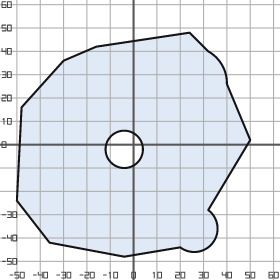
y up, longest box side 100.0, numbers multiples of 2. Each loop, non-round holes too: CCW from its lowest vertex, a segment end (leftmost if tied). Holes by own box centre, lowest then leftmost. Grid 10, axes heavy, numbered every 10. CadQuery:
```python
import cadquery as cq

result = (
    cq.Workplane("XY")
    .moveTo(-4.0, -48.0)
    .lineTo(20.0, -44.0)
    .threePointArc((34.0, -42.0), (32.0, -28.0))
    .lineTo(50.0, 2.0)
    .lineTo(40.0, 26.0)
    .threePointArc((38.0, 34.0), (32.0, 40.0))
    .lineTo(24.0, 48.0)
    .lineTo(-16.0, 42.0)
    .lineTo(-30.0, 36.0)
    .lineTo(-48.0, 16.0)
    .lineTo(-50.0, -24.0)
    .lineTo(-36.0, -42.0)
    .close()
    .moveTo(-4.0, -2.0)
    .circle(8.0)
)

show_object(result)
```